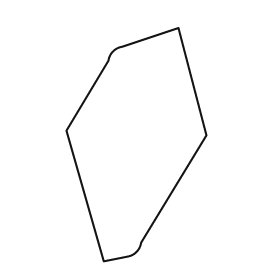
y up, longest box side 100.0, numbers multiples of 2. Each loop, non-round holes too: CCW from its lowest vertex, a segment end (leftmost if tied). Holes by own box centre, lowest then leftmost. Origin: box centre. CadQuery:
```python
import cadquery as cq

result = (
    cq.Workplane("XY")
    .moveTo(-14.0, -50.0)
    .lineTo(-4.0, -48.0)
    .threePointArc((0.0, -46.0), (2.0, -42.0))
    .lineTo(30.0, 4.0)
    .lineTo(18.0, 50.0)
    .lineTo(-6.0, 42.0)
    .threePointArc((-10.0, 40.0), (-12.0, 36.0))
    .lineTo(-30.0, 6.0)
    .close()
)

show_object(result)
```